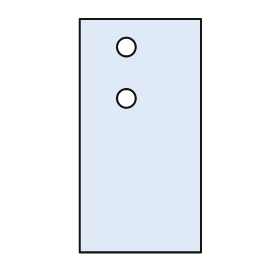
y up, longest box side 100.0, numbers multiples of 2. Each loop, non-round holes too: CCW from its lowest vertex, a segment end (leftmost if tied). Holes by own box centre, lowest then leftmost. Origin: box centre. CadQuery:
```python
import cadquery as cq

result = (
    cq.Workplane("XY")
    .moveTo(-26.0, -50.0)
    .lineTo(26.0, -50.0)
    .lineTo(26.0, 50.0)
    .lineTo(-26.0, 50.0)
    .close()
    .moveTo(-6.0, 16.0)
    .circle(4.0)
    .moveTo(-6.0, 38.0)
    .circle(4.0)
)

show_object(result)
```